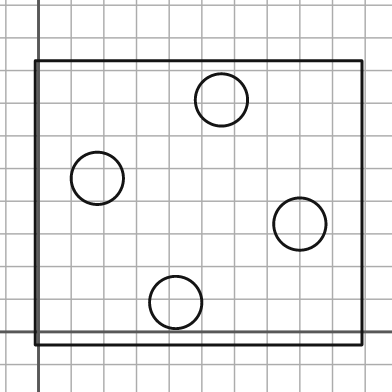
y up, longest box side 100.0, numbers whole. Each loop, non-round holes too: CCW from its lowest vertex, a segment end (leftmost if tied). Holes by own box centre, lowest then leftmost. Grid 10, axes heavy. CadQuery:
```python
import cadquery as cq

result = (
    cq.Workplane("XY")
    .moveTo(-1.0, -4.0)
    .lineTo(99.0, -4.0)
    .lineTo(99.0, 83.0)
    .lineTo(-1.0, 83.0)
    .close()
    .moveTo(42.0, 9.0)
    .circle(8.0)
    .moveTo(80.0, 33.0)
    .circle(8.0)
    .moveTo(18.0, 47.0)
    .circle(8.0)
    .moveTo(56.0, 71.0)
    .circle(8.0)
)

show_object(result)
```